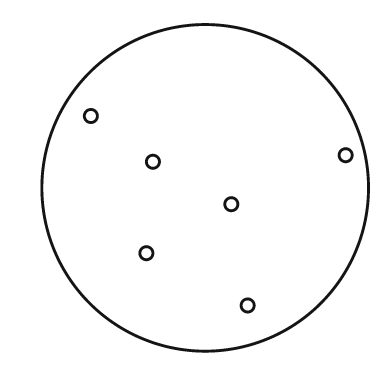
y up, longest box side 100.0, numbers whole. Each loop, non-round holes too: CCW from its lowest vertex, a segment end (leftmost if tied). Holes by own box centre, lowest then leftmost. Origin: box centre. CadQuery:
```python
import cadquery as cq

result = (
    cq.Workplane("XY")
    .moveTo(0.0, 0.0)
    .circle(50.0)
    .moveTo(13.0, -36.0)
    .circle(2.0)
    .moveTo(-18.0, -20.0)
    .circle(2.0)
    .moveTo(8.0, -5.0)
    .circle(2.0)
    .moveTo(-16.0, 8.0)
    .circle(2.0)
    .moveTo(43.0, 10.0)
    .circle(2.0)
    .moveTo(-35.0, 22.0)
    .circle(2.0)
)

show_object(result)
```